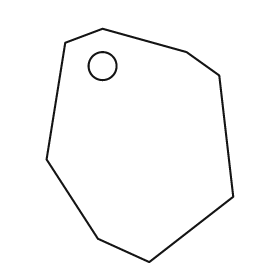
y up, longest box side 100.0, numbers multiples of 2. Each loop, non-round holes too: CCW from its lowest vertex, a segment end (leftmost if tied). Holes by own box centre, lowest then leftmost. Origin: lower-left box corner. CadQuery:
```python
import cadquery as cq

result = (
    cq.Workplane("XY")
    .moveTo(44.0, 0.0)
    .lineTo(80.0, 28.0)
    .lineTo(74.0, 80.0)
    .lineTo(60.0, 90.0)
    .lineTo(24.0, 100.0)
    .lineTo(8.0, 94.0)
    .lineTo(0.0, 44.0)
    .lineTo(22.0, 10.0)
    .close()
    .moveTo(24.0, 84.0)
    .circle(6.0)
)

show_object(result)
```